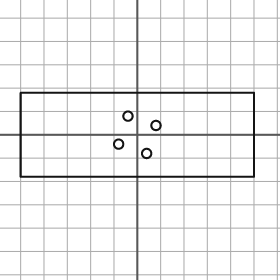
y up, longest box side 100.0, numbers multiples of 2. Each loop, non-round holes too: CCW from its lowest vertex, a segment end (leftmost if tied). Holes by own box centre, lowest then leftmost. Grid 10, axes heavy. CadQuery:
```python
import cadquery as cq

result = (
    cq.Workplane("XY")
    .moveTo(-50.0, -18.0)
    .lineTo(50.0, -18.0)
    .lineTo(50.0, 18.0)
    .lineTo(-50.0, 18.0)
    .close()
    .moveTo(4.0, -8.0)
    .circle(2.0)
    .moveTo(-8.0, -4.0)
    .circle(2.0)
    .moveTo(8.0, 4.0)
    .circle(2.0)
    .moveTo(-4.0, 8.0)
    .circle(2.0)
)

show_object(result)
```